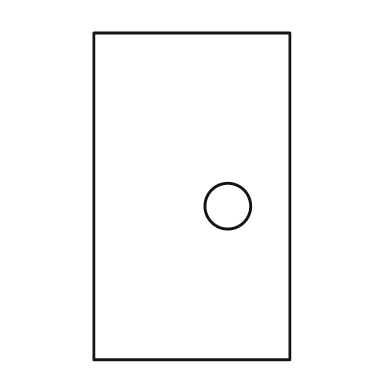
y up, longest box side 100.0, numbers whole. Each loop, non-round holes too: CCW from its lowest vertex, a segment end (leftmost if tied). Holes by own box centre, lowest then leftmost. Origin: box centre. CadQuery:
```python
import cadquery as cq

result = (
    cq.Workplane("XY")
    .moveTo(-30.0, -50.0)
    .lineTo(30.0, -50.0)
    .lineTo(30.0, 50.0)
    .lineTo(-30.0, 50.0)
    .close()
    .moveTo(11.0, -3.0)
    .circle(7.0)
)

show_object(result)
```